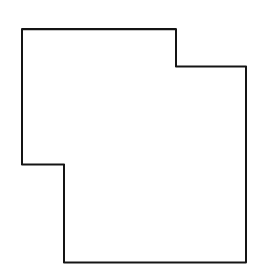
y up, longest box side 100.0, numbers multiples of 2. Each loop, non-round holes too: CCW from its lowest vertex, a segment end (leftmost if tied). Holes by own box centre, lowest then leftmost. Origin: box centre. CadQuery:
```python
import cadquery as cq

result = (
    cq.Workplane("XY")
    .moveTo(-30.0, -50.0)
    .lineTo(48.0, -50.0)
    .lineTo(48.0, 34.0)
    .lineTo(18.0, 34.0)
    .lineTo(18.0, 50.0)
    .lineTo(-48.0, 50.0)
    .lineTo(-48.0, -8.0)
    .lineTo(-30.0, -8.0)
    .close()
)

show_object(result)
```